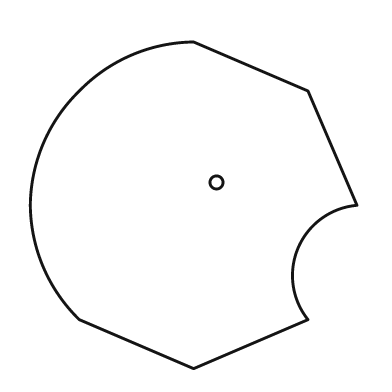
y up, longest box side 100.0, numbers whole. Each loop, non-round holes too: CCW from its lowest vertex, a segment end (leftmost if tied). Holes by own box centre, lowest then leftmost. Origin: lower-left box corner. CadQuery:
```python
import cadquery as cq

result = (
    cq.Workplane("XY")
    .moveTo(50.0, 0.0)
    .lineTo(85.0, 15.0)
    .threePointArc((82.0, 37.0), (100.0, 50.0))
    .lineTo(85.0, 85.0)
    .lineTo(50.0, 100.0)
    .threePointArc((31.0, 96.0), (15.0, 85.0))
    .threePointArc((4.0, 69.0), (0.0, 50.0))
    .threePointArc((4.0, 31.0), (15.0, 15.0))
    .close()
    .moveTo(57.0, 57.0)
    .circle(2.0)
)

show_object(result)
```